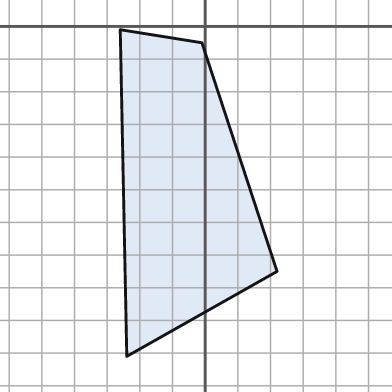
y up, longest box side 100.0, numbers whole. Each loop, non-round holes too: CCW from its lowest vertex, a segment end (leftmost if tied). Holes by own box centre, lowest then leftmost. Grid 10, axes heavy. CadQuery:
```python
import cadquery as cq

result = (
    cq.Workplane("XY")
    .moveTo(-24.0, -101.0)
    .lineTo(22.0, -75.0)
    .lineTo(-1.0, -5.0)
    .lineTo(-26.0, -1.0)
    .close()
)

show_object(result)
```